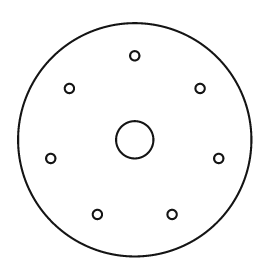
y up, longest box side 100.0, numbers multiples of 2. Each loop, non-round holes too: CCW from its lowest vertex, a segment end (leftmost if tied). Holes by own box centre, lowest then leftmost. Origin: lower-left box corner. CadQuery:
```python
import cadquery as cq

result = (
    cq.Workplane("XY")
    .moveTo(50.0, 50.0)
    .circle(50.0)
    .moveTo(34.0, 18.0)
    .circle(2.0)
    .moveTo(66.0, 18.0)
    .circle(2.0)
    .moveTo(14.0, 42.0)
    .circle(2.0)
    .moveTo(86.0, 42.0)
    .circle(2.0)
    .moveTo(50.0, 50.0)
    .circle(8.0)
    .moveTo(22.0, 72.0)
    .circle(2.0)
    .moveTo(78.0, 72.0)
    .circle(2.0)
    .moveTo(50.0, 86.0)
    .circle(2.0)
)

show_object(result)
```